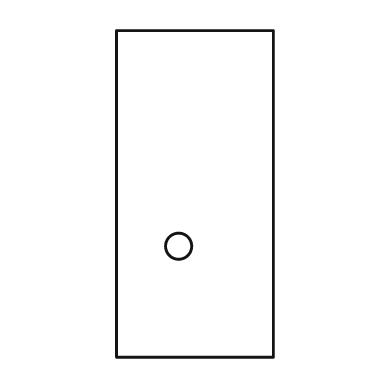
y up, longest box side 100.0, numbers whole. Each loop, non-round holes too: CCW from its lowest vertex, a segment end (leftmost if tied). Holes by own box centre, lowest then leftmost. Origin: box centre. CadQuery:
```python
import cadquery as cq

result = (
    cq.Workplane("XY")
    .moveTo(-24.0, -50.0)
    .lineTo(24.0, -50.0)
    .lineTo(24.0, 50.0)
    .lineTo(-24.0, 50.0)
    .close()
    .moveTo(-5.0, -16.0)
    .circle(4.0)
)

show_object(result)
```